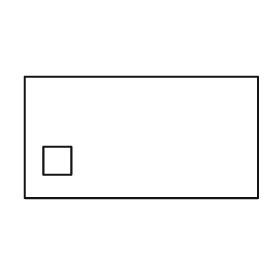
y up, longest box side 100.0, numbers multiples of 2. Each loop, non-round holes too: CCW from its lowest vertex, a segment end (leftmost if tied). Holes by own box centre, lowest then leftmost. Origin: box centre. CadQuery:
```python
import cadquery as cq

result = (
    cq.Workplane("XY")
    .moveTo(-50.0, -26.0)
    .lineTo(50.0, -26.0)
    .lineTo(50.0, 26.0)
    .lineTo(-50.0, 26.0)
    .close()
    .moveTo(-42.0, -16.0)
    .lineTo(-30.0, -16.0)
    .lineTo(-30.0, -4.0)
    .lineTo(-42.0, -4.0)
    .close()
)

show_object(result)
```